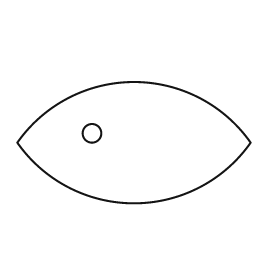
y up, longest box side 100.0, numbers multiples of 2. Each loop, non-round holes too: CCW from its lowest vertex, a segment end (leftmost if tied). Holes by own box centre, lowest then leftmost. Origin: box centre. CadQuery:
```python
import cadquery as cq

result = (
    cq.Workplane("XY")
    .moveTo(-50.0, 0.0)
    .threePointArc((0.0, -26.0), (50.0, 0.0))
    .threePointArc((0.0, 26.0), (-50.0, 0.0))
    .close()
    .moveTo(-18.0, 4.0)
    .circle(4.0)
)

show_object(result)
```